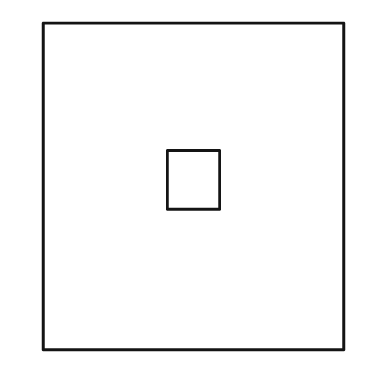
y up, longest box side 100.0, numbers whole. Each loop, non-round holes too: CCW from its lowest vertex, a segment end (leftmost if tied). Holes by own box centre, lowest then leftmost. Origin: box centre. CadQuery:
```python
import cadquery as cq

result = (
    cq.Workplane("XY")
    .moveTo(-46.0, -50.0)
    .lineTo(46.0, -50.0)
    .lineTo(46.0, 50.0)
    .lineTo(-46.0, 50.0)
    .close()
    .moveTo(-8.0, -7.0)
    .lineTo(8.0, -7.0)
    .lineTo(8.0, 11.0)
    .lineTo(-8.0, 11.0)
    .close()
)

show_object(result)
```